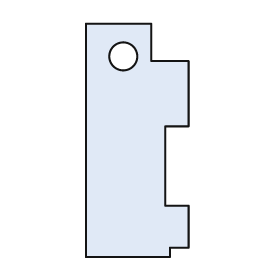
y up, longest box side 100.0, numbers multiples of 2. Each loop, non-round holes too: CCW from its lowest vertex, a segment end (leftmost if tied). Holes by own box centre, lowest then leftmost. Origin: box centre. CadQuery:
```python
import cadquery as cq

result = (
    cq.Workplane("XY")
    .moveTo(-22.0, -50.0)
    .lineTo(14.0, -50.0)
    .lineTo(14.0, -46.0)
    .lineTo(22.0, -46.0)
    .lineTo(22.0, -28.0)
    .lineTo(12.0, -28.0)
    .lineTo(12.0, 6.0)
    .lineTo(22.0, 6.0)
    .lineTo(22.0, 34.0)
    .lineTo(6.0, 34.0)
    .lineTo(6.0, 50.0)
    .lineTo(-22.0, 50.0)
    .close()
    .moveTo(-6.0, 36.0)
    .circle(6.0)
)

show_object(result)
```